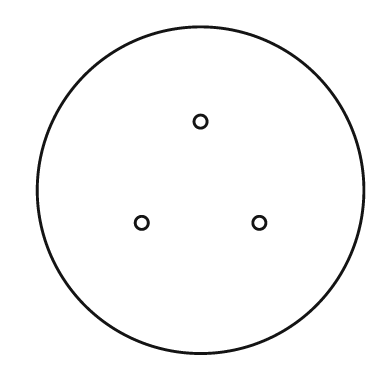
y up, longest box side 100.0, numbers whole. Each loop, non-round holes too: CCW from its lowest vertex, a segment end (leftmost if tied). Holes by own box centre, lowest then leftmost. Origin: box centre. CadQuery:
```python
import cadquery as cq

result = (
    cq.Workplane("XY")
    .moveTo(0.0, 0.0)
    .circle(50.0)
    .moveTo(-18.0, -10.0)
    .circle(2.0)
    .moveTo(18.0, -10.0)
    .circle(2.0)
    .moveTo(0.0, 21.0)
    .circle(2.0)
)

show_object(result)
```